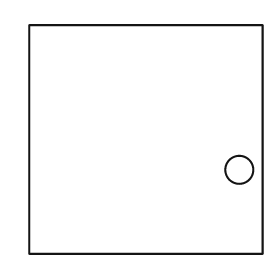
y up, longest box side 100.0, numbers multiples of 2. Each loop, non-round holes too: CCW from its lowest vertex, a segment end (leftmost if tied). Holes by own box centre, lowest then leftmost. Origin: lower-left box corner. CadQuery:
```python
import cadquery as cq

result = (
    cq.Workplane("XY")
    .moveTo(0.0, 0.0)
    .lineTo(100.0, 0.0)
    .lineTo(100.0, 98.0)
    .lineTo(0.0, 98.0)
    .close()
    .moveTo(90.0, 36.0)
    .circle(6.0)
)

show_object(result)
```